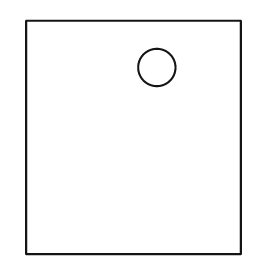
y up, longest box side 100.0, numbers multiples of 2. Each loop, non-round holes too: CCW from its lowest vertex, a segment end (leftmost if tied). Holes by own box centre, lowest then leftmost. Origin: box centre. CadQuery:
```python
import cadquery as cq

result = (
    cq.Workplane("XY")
    .moveTo(-46.0, -50.0)
    .lineTo(46.0, -50.0)
    .lineTo(46.0, 50.0)
    .lineTo(-46.0, 50.0)
    .close()
    .moveTo(10.0, 30.0)
    .circle(8.0)
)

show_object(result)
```